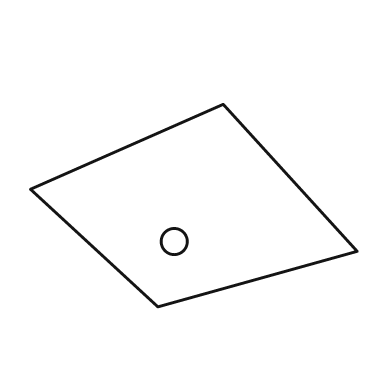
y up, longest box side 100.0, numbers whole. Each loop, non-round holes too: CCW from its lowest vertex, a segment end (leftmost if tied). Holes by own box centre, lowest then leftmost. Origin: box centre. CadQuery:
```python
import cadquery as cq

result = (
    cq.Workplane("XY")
    .moveTo(-11.0, -31.0)
    .lineTo(50.0, -14.0)
    .lineTo(9.0, 31.0)
    .lineTo(-50.0, 5.0)
    .close()
    .moveTo(-6.0, -11.0)
    .circle(4.0)
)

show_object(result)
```